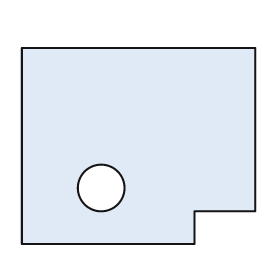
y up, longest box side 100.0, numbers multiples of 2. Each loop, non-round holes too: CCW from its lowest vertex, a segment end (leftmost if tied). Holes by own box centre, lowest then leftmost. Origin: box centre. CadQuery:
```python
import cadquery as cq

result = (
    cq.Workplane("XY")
    .moveTo(-50.0, -42.0)
    .lineTo(24.0, -42.0)
    .lineTo(24.0, -28.0)
    .lineTo(50.0, -28.0)
    .lineTo(50.0, 42.0)
    .lineTo(-50.0, 42.0)
    .close()
    .moveTo(-16.0, -18.0)
    .circle(10.0)
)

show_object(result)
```